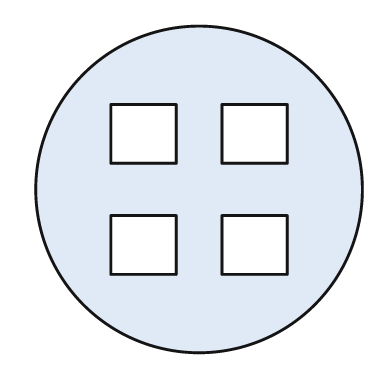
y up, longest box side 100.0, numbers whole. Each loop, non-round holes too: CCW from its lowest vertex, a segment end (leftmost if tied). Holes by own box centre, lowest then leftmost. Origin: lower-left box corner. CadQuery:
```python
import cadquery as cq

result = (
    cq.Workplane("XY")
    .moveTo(50.0, 50.0)
    .circle(50.0)
    .moveTo(23.0, 24.0)
    .lineTo(43.0, 24.0)
    .lineTo(43.0, 42.0)
    .lineTo(23.0, 42.0)
    .close()
    .moveTo(57.0, 24.0)
    .lineTo(77.0, 24.0)
    .lineTo(77.0, 42.0)
    .lineTo(57.0, 42.0)
    .close()
    .moveTo(23.0, 58.0)
    .lineTo(43.0, 58.0)
    .lineTo(43.0, 76.0)
    .lineTo(23.0, 76.0)
    .close()
    .moveTo(57.0, 58.0)
    .lineTo(77.0, 58.0)
    .lineTo(77.0, 76.0)
    .lineTo(57.0, 76.0)
    .close()
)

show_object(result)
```